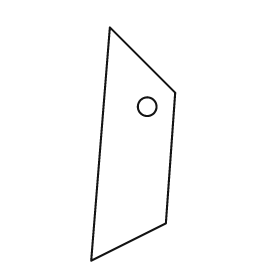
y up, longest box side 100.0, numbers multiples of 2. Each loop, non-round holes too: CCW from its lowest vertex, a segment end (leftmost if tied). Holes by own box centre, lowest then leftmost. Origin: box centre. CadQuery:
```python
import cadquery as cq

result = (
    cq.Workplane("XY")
    .moveTo(-18.0, -50.0)
    .lineTo(14.0, -34.0)
    .lineTo(18.0, 22.0)
    .lineTo(-10.0, 50.0)
    .close()
    .moveTo(6.0, 16.0)
    .circle(4.0)
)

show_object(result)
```